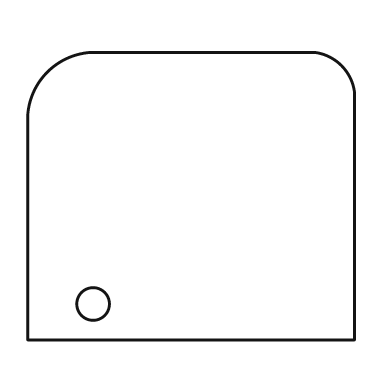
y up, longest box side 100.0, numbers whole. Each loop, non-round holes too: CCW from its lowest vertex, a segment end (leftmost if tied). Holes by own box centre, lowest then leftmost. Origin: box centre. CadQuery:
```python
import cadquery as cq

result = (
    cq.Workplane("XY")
    .moveTo(-50.0, -44.0)
    .lineTo(50.0, -44.0)
    .lineTo(50.0, 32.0)
    .threePointArc((46.0, 40.0), (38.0, 44.0))
    .lineTo(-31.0, 44.0)
    .threePointArc((-44.0, 38.0), (-50.0, 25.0))
    .close()
    .moveTo(-30.0, -33.0)
    .circle(5.0)
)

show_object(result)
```